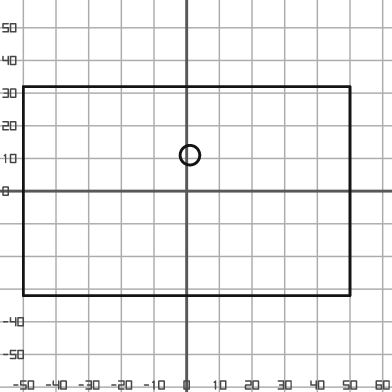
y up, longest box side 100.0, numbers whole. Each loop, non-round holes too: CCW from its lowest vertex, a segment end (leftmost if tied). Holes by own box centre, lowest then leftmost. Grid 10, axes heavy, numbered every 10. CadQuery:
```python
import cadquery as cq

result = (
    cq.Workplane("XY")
    .moveTo(-50.0, -32.0)
    .lineTo(50.0, -32.0)
    .lineTo(50.0, 32.0)
    .lineTo(-50.0, 32.0)
    .close()
    .moveTo(1.0, 11.0)
    .circle(3.0)
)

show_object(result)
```